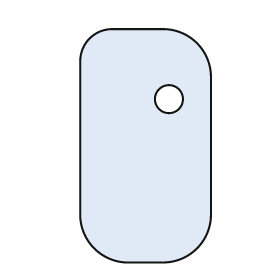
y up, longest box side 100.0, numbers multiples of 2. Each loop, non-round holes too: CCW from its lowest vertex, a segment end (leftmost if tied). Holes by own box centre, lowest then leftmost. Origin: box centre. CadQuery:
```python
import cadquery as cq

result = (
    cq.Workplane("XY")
    .moveTo(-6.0, -50.0)
    .lineTo(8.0, -50.0)
    .threePointArc((22.0, -44.0), (28.0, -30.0))
    .lineTo(28.0, 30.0)
    .threePointArc((22.0, 44.0), (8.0, 50.0))
    .lineTo(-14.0, 50.0)
    .threePointArc((-24.0, 46.0), (-28.0, 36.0))
    .lineTo(-28.0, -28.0)
    .threePointArc((-22.0, -44.0), (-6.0, -50.0))
    .close()
    .moveTo(10.0, 20.0)
    .circle(6.0)
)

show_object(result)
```